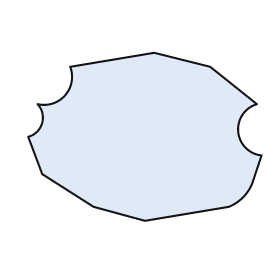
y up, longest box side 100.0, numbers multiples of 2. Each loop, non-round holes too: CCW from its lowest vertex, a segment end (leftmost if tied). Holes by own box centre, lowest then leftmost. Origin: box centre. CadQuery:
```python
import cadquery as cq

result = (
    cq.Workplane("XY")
    .moveTo(0.0, -36.0)
    .lineTo(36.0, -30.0)
    .threePointArc((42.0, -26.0), (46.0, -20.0))
    .lineTo(50.0, -8.0)
    .threePointArc((40.0, 2.0), (48.0, 14.0))
    .lineTo(28.0, 30.0)
    .lineTo(4.0, 36.0)
    .lineTo(-32.0, 30.0)
    .threePointArc((-34.0, 18.0), (-46.0, 14.0))
    .threePointArc((-44.0, 6.0), (-50.0, 0.0))
    .lineTo(-44.0, -16.0)
    .lineTo(-22.0, -30.0)
    .close()
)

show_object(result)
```